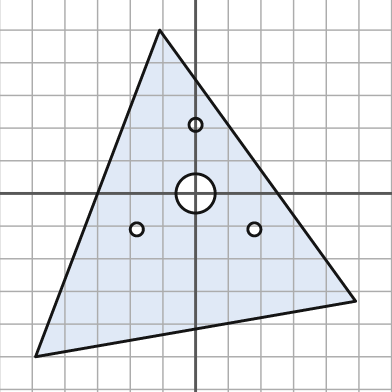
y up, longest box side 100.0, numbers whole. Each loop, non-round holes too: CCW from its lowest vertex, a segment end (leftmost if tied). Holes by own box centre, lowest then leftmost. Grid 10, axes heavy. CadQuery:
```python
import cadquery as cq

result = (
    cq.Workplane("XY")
    .moveTo(-49.0, -50.0)
    .lineTo(49.0, -33.0)
    .lineTo(-11.0, 50.0)
    .close()
    .moveTo(-18.0, -11.0)
    .circle(2.0)
    .moveTo(18.0, -11.0)
    .circle(2.0)
    .moveTo(0.0, 0.0)
    .circle(6.0)
    .moveTo(0.0, 21.0)
    .circle(2.0)
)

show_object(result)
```